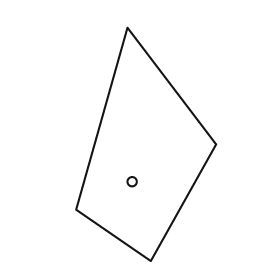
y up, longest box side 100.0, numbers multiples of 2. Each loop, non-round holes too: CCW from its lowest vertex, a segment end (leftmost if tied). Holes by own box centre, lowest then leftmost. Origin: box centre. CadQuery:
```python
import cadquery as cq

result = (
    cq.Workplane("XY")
    .moveTo(2.0, -50.0)
    .lineTo(30.0, 0.0)
    .lineTo(-8.0, 50.0)
    .lineTo(-30.0, -28.0)
    .close()
    .moveTo(-6.0, -16.0)
    .circle(2.0)
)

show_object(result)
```